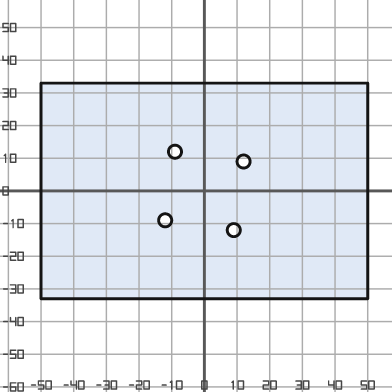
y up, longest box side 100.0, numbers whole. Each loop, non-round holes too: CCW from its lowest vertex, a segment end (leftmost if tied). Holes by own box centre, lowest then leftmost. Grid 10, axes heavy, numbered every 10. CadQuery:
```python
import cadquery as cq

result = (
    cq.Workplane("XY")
    .moveTo(-50.0, -33.0)
    .lineTo(50.0, -33.0)
    .lineTo(50.0, 33.0)
    .lineTo(-50.0, 33.0)
    .close()
    .moveTo(9.0, -12.0)
    .circle(2.0)
    .moveTo(-12.0, -9.0)
    .circle(2.0)
    .moveTo(12.0, 9.0)
    .circle(2.0)
    .moveTo(-9.0, 12.0)
    .circle(2.0)
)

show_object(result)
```